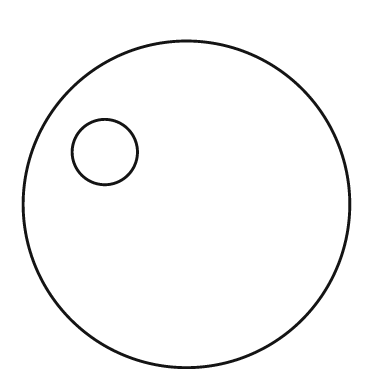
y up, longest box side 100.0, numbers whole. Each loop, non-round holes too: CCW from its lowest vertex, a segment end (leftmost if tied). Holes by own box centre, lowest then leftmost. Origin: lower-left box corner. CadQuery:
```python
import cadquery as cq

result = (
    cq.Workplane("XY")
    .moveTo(50.0, 50.0)
    .circle(50.0)
    .moveTo(25.0, 66.0)
    .circle(10.0)
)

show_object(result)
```